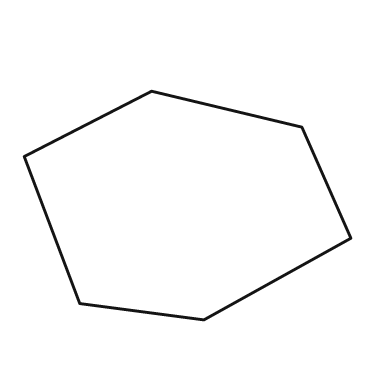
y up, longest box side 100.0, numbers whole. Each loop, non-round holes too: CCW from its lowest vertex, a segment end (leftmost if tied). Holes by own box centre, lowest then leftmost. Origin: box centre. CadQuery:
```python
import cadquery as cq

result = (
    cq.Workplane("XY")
    .moveTo(5.0, -35.0)
    .lineTo(50.0, -10.0)
    .lineTo(35.0, 24.0)
    .lineTo(-11.0, 35.0)
    .lineTo(-50.0, 15.0)
    .lineTo(-33.0, -30.0)
    .close()
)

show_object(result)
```